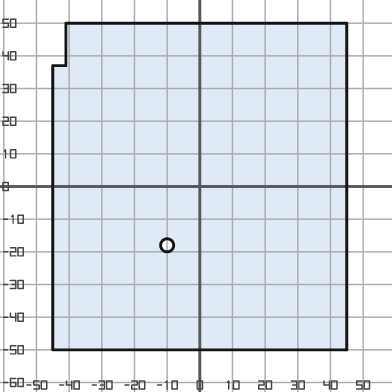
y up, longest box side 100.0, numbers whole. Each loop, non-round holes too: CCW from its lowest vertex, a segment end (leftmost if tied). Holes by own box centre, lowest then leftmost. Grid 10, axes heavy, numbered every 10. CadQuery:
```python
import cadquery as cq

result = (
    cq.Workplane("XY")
    .moveTo(-45.0, -50.0)
    .lineTo(45.0, -50.0)
    .lineTo(45.0, 50.0)
    .lineTo(-41.0, 50.0)
    .lineTo(-41.0, 37.0)
    .lineTo(-45.0, 37.0)
    .close()
    .moveTo(-10.0, -18.0)
    .circle(2.0)
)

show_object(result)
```